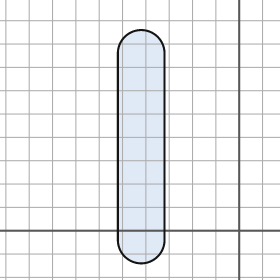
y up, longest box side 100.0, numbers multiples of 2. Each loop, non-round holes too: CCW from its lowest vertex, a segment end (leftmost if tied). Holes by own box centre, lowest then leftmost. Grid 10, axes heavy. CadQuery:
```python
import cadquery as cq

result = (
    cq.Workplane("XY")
    .moveTo(-52.0, -4.0)
    .threePointArc((-42.0, -14.0), (-32.0, -4.0))
    .lineTo(-32.0, 76.0)
    .threePointArc((-42.0, 86.0), (-52.0, 76.0))
    .close()
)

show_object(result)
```